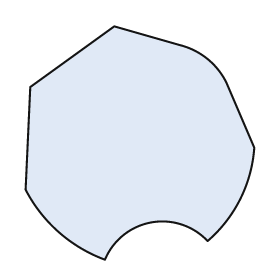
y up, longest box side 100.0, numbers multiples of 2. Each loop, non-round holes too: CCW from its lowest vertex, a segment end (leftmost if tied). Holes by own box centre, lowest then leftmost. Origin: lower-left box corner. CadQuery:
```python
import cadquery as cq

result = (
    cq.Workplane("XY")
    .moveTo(34.0, 0.0)
    .threePointArc((54.0, 16.0), (78.0, 8.0))
    .threePointArc((92.0, 26.0), (98.0, 48.0))
    .lineTo(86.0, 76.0)
    .threePointArc((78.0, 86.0), (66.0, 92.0))
    .lineTo(38.0, 100.0)
    .lineTo(2.0, 74.0)
    .lineTo(0.0, 30.0)
    .threePointArc((14.0, 12.0), (34.0, 0.0))
    .close()
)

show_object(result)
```